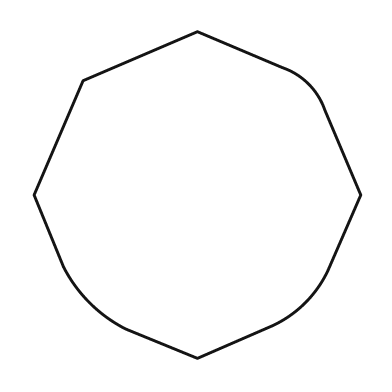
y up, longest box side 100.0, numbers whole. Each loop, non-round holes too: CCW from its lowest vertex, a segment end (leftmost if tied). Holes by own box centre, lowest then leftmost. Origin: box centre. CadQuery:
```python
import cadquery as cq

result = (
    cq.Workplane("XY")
    .moveTo(0.0, -50.0)
    .lineTo(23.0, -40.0)
    .threePointArc((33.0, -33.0), (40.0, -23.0))
    .lineTo(50.0, 0.0)
    .lineTo(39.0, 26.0)
    .threePointArc((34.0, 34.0), (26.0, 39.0))
    .lineTo(0.0, 50.0)
    .lineTo(-35.0, 35.0)
    .lineTo(-50.0, 0.0)
    .lineTo(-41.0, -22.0)
    .threePointArc((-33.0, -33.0), (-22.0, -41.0))
    .close()
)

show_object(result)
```